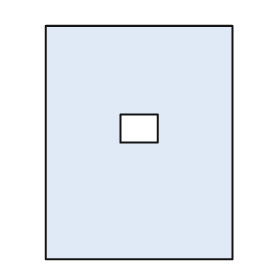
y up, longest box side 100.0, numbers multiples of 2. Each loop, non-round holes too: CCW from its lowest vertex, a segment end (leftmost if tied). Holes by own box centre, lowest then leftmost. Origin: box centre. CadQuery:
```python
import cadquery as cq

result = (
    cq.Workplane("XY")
    .moveTo(-40.0, -50.0)
    .lineTo(40.0, -50.0)
    .lineTo(40.0, 50.0)
    .lineTo(-40.0, 50.0)
    .close()
    .moveTo(-8.0, 0.0)
    .lineTo(8.0, 0.0)
    .lineTo(8.0, 12.0)
    .lineTo(-8.0, 12.0)
    .close()
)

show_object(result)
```